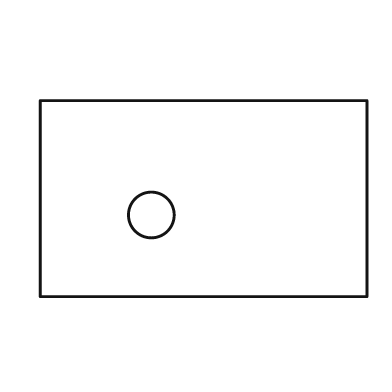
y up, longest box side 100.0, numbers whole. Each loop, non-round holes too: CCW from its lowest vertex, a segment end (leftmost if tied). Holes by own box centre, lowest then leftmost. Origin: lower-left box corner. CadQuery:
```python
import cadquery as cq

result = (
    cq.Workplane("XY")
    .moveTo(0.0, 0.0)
    .lineTo(100.0, 0.0)
    .lineTo(100.0, 60.0)
    .lineTo(0.0, 60.0)
    .close()
    .moveTo(34.0, 25.0)
    .circle(7.0)
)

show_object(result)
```